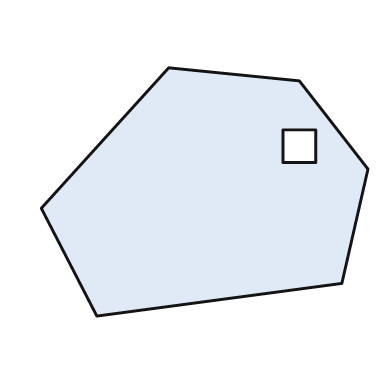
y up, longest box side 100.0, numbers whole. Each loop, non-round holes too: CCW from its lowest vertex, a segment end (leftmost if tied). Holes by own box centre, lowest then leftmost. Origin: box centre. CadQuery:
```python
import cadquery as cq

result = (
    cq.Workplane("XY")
    .moveTo(-33.0, -38.0)
    .lineTo(42.0, -28.0)
    .lineTo(50.0, 7.0)
    .lineTo(29.0, 34.0)
    .lineTo(-11.0, 38.0)
    .lineTo(-50.0, -5.0)
    .close()
    .moveTo(24.0, 9.0)
    .lineTo(34.0, 9.0)
    .lineTo(34.0, 19.0)
    .lineTo(24.0, 19.0)
    .close()
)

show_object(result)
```